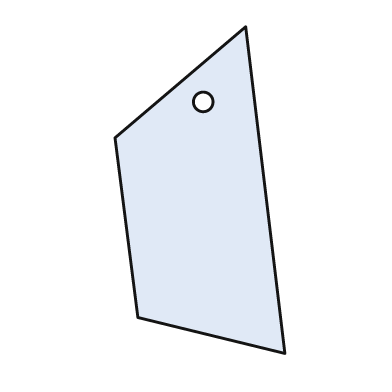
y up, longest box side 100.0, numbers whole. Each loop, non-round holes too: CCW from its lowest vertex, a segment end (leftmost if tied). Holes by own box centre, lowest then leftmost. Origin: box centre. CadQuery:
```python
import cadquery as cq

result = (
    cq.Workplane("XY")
    .moveTo(26.0, -50.0)
    .lineTo(14.0, 50.0)
    .lineTo(-26.0, 16.0)
    .lineTo(-19.0, -39.0)
    .close()
    .moveTo(1.0, 27.0)
    .circle(3.0)
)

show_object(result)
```